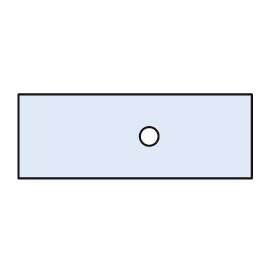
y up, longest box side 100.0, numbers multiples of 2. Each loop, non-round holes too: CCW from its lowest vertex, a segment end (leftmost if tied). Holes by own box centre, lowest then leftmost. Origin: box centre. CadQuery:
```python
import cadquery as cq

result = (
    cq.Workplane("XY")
    .moveTo(-50.0, -18.0)
    .lineTo(50.0, -18.0)
    .lineTo(50.0, 18.0)
    .lineTo(-50.0, 18.0)
    .close()
    .moveTo(6.0, 0.0)
    .circle(4.0)
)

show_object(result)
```